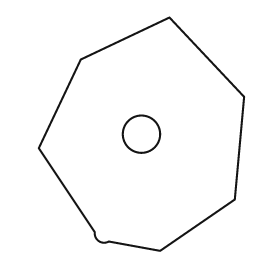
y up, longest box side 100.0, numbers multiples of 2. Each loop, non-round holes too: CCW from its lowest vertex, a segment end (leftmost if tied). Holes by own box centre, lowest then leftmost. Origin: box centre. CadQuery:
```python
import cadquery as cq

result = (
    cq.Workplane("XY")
    .moveTo(8.0, -50.0)
    .lineTo(40.0, -28.0)
    .lineTo(44.0, 16.0)
    .lineTo(12.0, 50.0)
    .lineTo(-26.0, 32.0)
    .lineTo(-44.0, -6.0)
    .lineTo(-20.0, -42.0)
    .threePointArc((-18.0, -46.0), (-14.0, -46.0))
    .close()
    .moveTo(0.0, 0.0)
    .circle(8.0)
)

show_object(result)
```